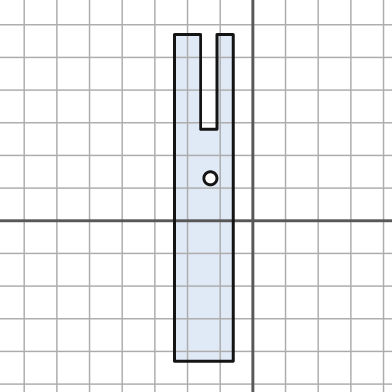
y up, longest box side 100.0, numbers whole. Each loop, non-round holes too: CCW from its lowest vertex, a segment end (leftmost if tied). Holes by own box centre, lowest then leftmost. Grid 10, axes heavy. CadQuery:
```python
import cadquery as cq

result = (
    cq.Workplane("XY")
    .moveTo(-24.0, -43.0)
    .lineTo(-6.0, -43.0)
    .lineTo(-6.0, 57.0)
    .lineTo(-11.0, 57.0)
    .lineTo(-11.0, 28.0)
    .lineTo(-16.0, 28.0)
    .lineTo(-16.0, 57.0)
    .lineTo(-24.0, 57.0)
    .close()
    .moveTo(-13.0, 13.0)
    .circle(2.0)
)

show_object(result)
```